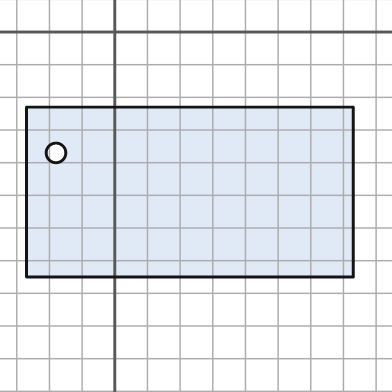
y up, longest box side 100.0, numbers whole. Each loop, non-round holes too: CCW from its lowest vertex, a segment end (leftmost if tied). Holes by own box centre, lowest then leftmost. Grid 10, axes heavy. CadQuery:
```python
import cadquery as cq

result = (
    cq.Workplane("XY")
    .moveTo(-27.0, -75.0)
    .lineTo(73.0, -75.0)
    .lineTo(73.0, -23.0)
    .lineTo(-27.0, -23.0)
    .close()
    .moveTo(-18.0, -37.0)
    .circle(3.0)
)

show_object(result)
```